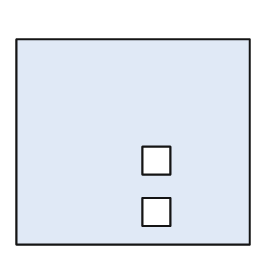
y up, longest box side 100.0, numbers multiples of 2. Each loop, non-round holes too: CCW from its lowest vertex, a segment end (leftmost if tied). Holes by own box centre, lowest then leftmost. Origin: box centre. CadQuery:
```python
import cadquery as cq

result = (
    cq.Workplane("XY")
    .moveTo(-50.0, -44.0)
    .lineTo(50.0, -44.0)
    .lineTo(50.0, 44.0)
    .lineTo(-50.0, 44.0)
    .close()
    .moveTo(4.0, -36.0)
    .lineTo(16.0, -36.0)
    .lineTo(16.0, -24.0)
    .lineTo(4.0, -24.0)
    .close()
    .moveTo(4.0, -14.0)
    .lineTo(16.0, -14.0)
    .lineTo(16.0, -2.0)
    .lineTo(4.0, -2.0)
    .close()
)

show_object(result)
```